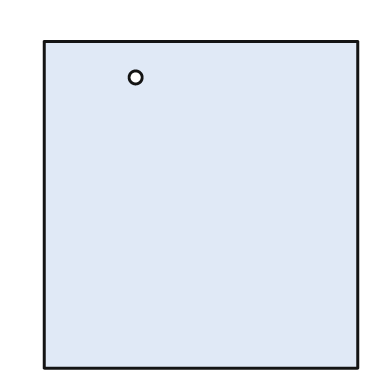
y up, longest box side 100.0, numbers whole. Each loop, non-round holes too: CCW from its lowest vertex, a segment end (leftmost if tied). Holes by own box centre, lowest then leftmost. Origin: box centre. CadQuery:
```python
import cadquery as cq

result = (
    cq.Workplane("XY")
    .moveTo(-48.0, -50.0)
    .lineTo(48.0, -50.0)
    .lineTo(48.0, 50.0)
    .lineTo(-48.0, 50.0)
    .close()
    .moveTo(-20.0, 39.0)
    .circle(2.0)
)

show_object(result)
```